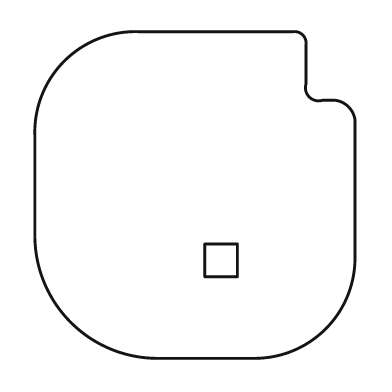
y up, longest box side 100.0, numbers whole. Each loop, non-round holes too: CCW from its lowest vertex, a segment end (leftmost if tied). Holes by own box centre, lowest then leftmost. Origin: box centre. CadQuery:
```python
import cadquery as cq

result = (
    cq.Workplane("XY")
    .moveTo(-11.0, -50.0)
    .lineTo(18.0, -50.0)
    .threePointArc((40.0, -41.0), (49.0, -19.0))
    .lineTo(49.0, 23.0)
    .threePointArc((47.0, 27.0), (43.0, 29.0))
    .lineTo(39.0, 29.0)
    .threePointArc((35.0, 30.0), (34.0, 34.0))
    .lineTo(34.0, 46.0)
    .threePointArc((33.0, 49.0), (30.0, 50.0))
    .lineTo(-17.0, 50.0)
    .threePointArc((-40.0, 41.0), (-49.0, 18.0))
    .lineTo(-49.0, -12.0)
    .threePointArc((-38.0, -39.0), (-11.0, -50.0))
    .close()
    .moveTo(3.0, -25.0)
    .lineTo(13.0, -25.0)
    .lineTo(13.0, -15.0)
    .lineTo(3.0, -15.0)
    .close()
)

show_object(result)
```